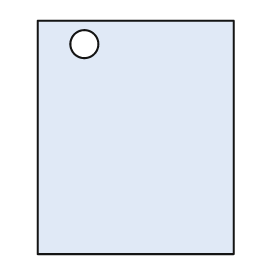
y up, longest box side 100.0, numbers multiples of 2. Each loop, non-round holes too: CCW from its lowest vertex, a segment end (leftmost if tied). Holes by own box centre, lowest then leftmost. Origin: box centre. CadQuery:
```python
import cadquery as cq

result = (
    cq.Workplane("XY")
    .moveTo(-42.0, -50.0)
    .lineTo(42.0, -50.0)
    .lineTo(42.0, 50.0)
    .lineTo(-42.0, 50.0)
    .close()
    .moveTo(-22.0, 40.0)
    .circle(6.0)
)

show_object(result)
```